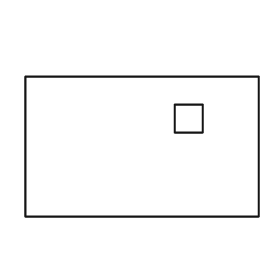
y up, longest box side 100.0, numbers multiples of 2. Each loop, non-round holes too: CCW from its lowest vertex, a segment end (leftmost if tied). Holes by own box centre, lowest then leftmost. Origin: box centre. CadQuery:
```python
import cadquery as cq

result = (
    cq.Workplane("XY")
    .moveTo(-50.0, -30.0)
    .lineTo(50.0, -30.0)
    .lineTo(50.0, 30.0)
    .lineTo(-50.0, 30.0)
    .close()
    .moveTo(14.0, 6.0)
    .lineTo(26.0, 6.0)
    .lineTo(26.0, 18.0)
    .lineTo(14.0, 18.0)
    .close()
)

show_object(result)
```